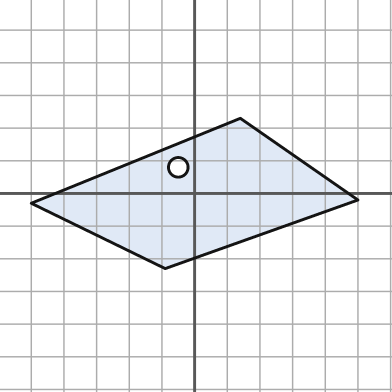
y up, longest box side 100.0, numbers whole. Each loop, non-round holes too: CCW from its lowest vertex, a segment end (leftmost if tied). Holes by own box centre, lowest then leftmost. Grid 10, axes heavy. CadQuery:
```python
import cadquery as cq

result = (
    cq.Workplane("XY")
    .moveTo(-9.0, -23.0)
    .lineTo(50.0, -2.0)
    .lineTo(14.0, 23.0)
    .lineTo(-50.0, -3.0)
    .close()
    .moveTo(-5.0, 8.0)
    .circle(3.0)
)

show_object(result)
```